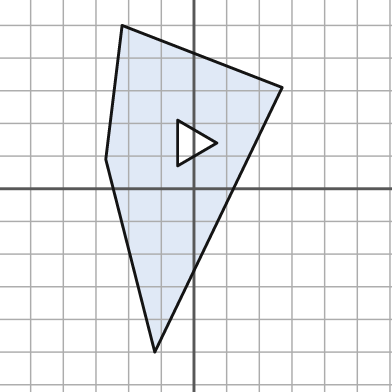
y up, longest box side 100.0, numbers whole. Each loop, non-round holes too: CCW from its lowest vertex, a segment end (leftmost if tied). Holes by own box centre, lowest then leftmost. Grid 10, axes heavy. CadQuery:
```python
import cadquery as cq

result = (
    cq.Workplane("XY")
    .moveTo(-12.0, -50.0)
    .lineTo(27.0, 31.0)
    .lineTo(-22.0, 50.0)
    .lineTo(-27.0, 9.0)
    .close()
    .moveTo(-5.0, 7.0)
    .lineTo(7.0, 14.0)
    .lineTo(-5.0, 21.0)
    .close()
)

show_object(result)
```